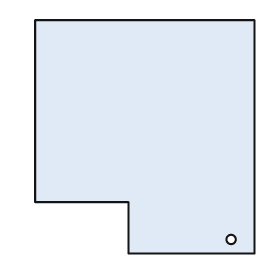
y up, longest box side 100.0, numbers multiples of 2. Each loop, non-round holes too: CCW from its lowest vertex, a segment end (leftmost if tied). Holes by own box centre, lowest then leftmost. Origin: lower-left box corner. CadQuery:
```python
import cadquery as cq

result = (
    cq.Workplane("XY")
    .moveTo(40.0, 0.0)
    .lineTo(94.0, 0.0)
    .lineTo(94.0, 100.0)
    .lineTo(0.0, 100.0)
    .lineTo(0.0, 22.0)
    .lineTo(40.0, 22.0)
    .close()
    .moveTo(84.0, 6.0)
    .circle(2.0)
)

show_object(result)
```